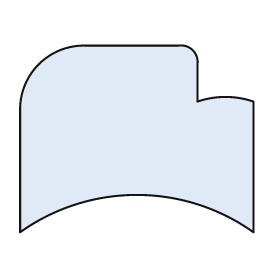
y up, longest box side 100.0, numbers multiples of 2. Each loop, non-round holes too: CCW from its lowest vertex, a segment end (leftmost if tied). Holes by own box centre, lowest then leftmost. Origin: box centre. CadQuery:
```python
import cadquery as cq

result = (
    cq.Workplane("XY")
    .moveTo(-50.0, -40.0)
    .threePointArc((0.0, -24.0), (50.0, -40.0))
    .lineTo(50.0, 16.0)
    .threePointArc((38.0, 18.0), (26.0, 16.0))
    .lineTo(26.0, 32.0)
    .threePointArc((24.0, 38.0), (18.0, 40.0))
    .lineTo(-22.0, 40.0)
    .threePointArc((-42.0, 32.0), (-50.0, 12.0))
    .close()
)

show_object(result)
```